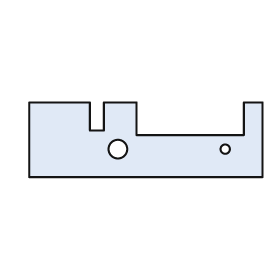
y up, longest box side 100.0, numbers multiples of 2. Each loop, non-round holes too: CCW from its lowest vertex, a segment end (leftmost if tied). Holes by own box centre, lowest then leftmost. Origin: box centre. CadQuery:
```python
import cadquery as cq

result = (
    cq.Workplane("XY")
    .moveTo(-50.0, -16.0)
    .lineTo(50.0, -16.0)
    .lineTo(50.0, 16.0)
    .lineTo(42.0, 16.0)
    .lineTo(42.0, 2.0)
    .lineTo(-4.0, 2.0)
    .lineTo(-4.0, 16.0)
    .lineTo(-18.0, 16.0)
    .lineTo(-18.0, 4.0)
    .lineTo(-24.0, 4.0)
    .lineTo(-24.0, 16.0)
    .lineTo(-50.0, 16.0)
    .close()
    .moveTo(-12.0, -4.0)
    .circle(4.0)
    .moveTo(34.0, -4.0)
    .circle(2.0)
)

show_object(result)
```